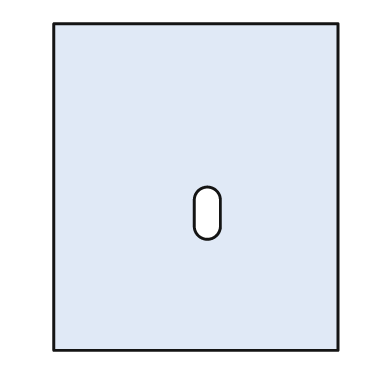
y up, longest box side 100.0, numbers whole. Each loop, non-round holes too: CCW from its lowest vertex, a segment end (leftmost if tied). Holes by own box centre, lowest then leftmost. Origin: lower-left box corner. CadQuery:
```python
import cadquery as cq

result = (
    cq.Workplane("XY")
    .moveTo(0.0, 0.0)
    .lineTo(87.0, 0.0)
    .lineTo(87.0, 100.0)
    .lineTo(0.0, 100.0)
    .close()
    .moveTo(43.0, 38.0)
    .threePointArc((47.0, 34.0), (51.0, 38.0))
    .lineTo(51.0, 46.0)
    .threePointArc((47.0, 50.0), (43.0, 46.0))
    .close()
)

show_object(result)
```